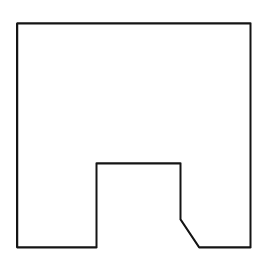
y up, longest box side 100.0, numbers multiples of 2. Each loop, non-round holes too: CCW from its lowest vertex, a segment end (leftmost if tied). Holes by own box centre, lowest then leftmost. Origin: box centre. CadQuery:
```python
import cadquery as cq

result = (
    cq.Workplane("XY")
    .moveTo(-50.0, -48.0)
    .lineTo(-16.0, -48.0)
    .lineTo(-16.0, -12.0)
    .lineTo(20.0, -12.0)
    .lineTo(20.0, -36.0)
    .lineTo(28.0, -48.0)
    .lineTo(50.0, -48.0)
    .lineTo(50.0, 48.0)
    .lineTo(-50.0, 48.0)
    .close()
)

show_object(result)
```